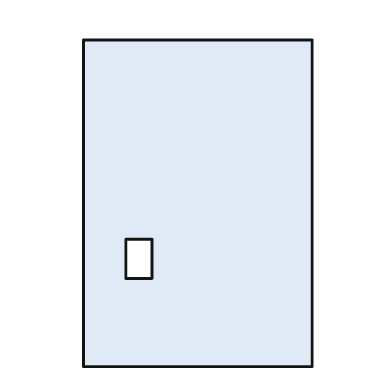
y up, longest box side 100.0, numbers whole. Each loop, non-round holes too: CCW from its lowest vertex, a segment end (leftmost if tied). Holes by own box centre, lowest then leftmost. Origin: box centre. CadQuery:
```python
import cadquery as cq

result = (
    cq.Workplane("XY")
    .moveTo(-35.0, -50.0)
    .lineTo(35.0, -50.0)
    .lineTo(35.0, 50.0)
    .lineTo(-35.0, 50.0)
    .close()
    .moveTo(-22.0, -23.0)
    .lineTo(-14.0, -23.0)
    .lineTo(-14.0, -11.0)
    .lineTo(-22.0, -11.0)
    .close()
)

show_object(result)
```